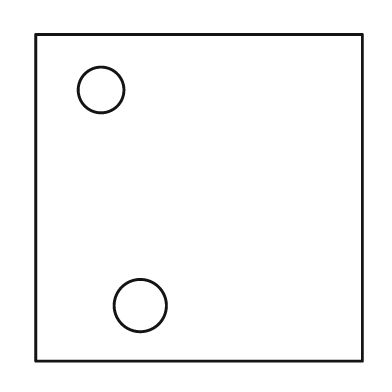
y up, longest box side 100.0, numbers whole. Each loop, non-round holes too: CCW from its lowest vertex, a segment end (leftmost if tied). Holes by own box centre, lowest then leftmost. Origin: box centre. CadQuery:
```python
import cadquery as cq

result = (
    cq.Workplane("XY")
    .moveTo(-50.0, -50.0)
    .lineTo(50.0, -50.0)
    .lineTo(50.0, 50.0)
    .lineTo(-50.0, 50.0)
    .close()
    .moveTo(-18.0, -33.0)
    .circle(8.0)
    .moveTo(-30.0, 33.0)
    .circle(7.0)
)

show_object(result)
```